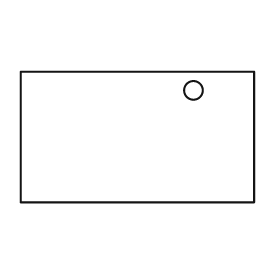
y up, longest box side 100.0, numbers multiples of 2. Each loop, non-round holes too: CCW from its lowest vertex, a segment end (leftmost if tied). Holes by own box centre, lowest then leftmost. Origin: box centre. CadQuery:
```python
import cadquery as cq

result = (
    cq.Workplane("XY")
    .moveTo(-50.0, -28.0)
    .lineTo(50.0, -28.0)
    .lineTo(50.0, 28.0)
    .lineTo(-50.0, 28.0)
    .close()
    .moveTo(24.0, 20.0)
    .circle(4.0)
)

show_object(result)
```